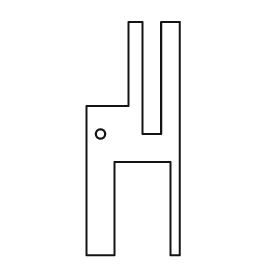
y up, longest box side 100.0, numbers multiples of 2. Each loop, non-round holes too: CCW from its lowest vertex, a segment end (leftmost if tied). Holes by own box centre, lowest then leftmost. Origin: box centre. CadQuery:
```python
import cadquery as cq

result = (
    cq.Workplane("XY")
    .moveTo(-20.0, -50.0)
    .lineTo(-8.0, -50.0)
    .lineTo(-8.0, -10.0)
    .lineTo(16.0, -10.0)
    .lineTo(16.0, -50.0)
    .lineTo(20.0, -50.0)
    .lineTo(20.0, 50.0)
    .lineTo(12.0, 50.0)
    .lineTo(12.0, 2.0)
    .lineTo(4.0, 2.0)
    .lineTo(4.0, 50.0)
    .lineTo(-2.0, 50.0)
    .lineTo(-2.0, 14.0)
    .lineTo(-20.0, 14.0)
    .close()
    .moveTo(-14.0, 2.0)
    .circle(2.0)
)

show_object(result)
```